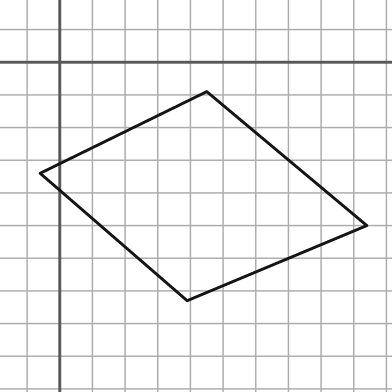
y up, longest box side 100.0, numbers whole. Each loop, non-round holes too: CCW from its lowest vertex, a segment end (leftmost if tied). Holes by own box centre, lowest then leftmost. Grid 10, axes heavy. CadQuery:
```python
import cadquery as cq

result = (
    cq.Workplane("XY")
    .moveTo(39.0, -73.0)
    .lineTo(94.0, -50.0)
    .lineTo(45.0, -9.0)
    .lineTo(-6.0, -34.0)
    .close()
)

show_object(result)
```